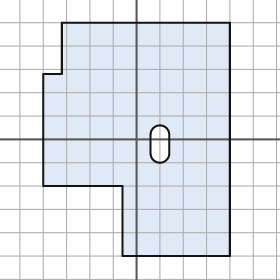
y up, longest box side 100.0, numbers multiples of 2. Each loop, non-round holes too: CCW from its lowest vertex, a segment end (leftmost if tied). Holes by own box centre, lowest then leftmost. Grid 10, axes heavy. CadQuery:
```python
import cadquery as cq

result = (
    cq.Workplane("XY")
    .moveTo(-6.0, -50.0)
    .lineTo(40.0, -50.0)
    .lineTo(40.0, 50.0)
    .lineTo(-32.0, 50.0)
    .lineTo(-32.0, 28.0)
    .lineTo(-40.0, 28.0)
    .lineTo(-40.0, -20.0)
    .lineTo(-6.0, -20.0)
    .close()
    .moveTo(6.0, -6.0)
    .threePointArc((10.0, -10.0), (14.0, -6.0))
    .lineTo(14.0, 2.0)
    .threePointArc((10.0, 6.0), (6.0, 2.0))
    .close()
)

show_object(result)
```